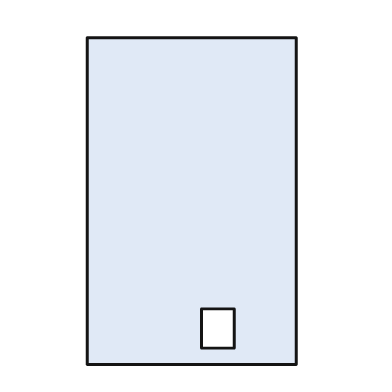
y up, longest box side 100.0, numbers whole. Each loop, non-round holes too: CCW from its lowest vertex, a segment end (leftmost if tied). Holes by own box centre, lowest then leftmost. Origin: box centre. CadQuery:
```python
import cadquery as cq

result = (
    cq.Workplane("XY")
    .moveTo(-32.0, -50.0)
    .lineTo(32.0, -50.0)
    .lineTo(32.0, 50.0)
    .lineTo(-32.0, 50.0)
    .close()
    .moveTo(3.0, -45.0)
    .lineTo(13.0, -45.0)
    .lineTo(13.0, -33.0)
    .lineTo(3.0, -33.0)
    .close()
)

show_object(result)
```